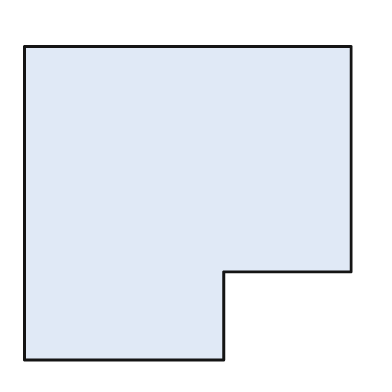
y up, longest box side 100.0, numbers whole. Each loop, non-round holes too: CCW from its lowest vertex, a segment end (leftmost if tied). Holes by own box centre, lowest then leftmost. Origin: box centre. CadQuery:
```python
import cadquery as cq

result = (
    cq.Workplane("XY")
    .moveTo(-50.0, -48.0)
    .lineTo(11.0, -48.0)
    .lineTo(11.0, -21.0)
    .lineTo(50.0, -21.0)
    .lineTo(50.0, 48.0)
    .lineTo(-50.0, 48.0)
    .close()
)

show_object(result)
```